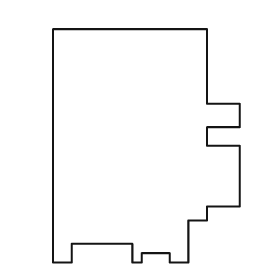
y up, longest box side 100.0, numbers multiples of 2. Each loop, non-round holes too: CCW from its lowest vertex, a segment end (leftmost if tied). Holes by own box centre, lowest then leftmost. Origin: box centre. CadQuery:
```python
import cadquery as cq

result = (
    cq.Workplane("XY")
    .moveTo(-40.0, -50.0)
    .lineTo(-32.0, -50.0)
    .lineTo(-32.0, -42.0)
    .lineTo(-6.0, -42.0)
    .lineTo(-6.0, -50.0)
    .lineTo(-2.0, -50.0)
    .lineTo(-2.0, -46.0)
    .lineTo(10.0, -46.0)
    .lineTo(10.0, -50.0)
    .lineTo(18.0, -50.0)
    .lineTo(18.0, -32.0)
    .lineTo(26.0, -32.0)
    .lineTo(26.0, -26.0)
    .lineTo(40.0, -26.0)
    .lineTo(40.0, 0.0)
    .lineTo(26.0, 0.0)
    .lineTo(26.0, 8.0)
    .lineTo(40.0, 8.0)
    .lineTo(40.0, 18.0)
    .lineTo(26.0, 18.0)
    .lineTo(26.0, 50.0)
    .lineTo(-40.0, 50.0)
    .close()
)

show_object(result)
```